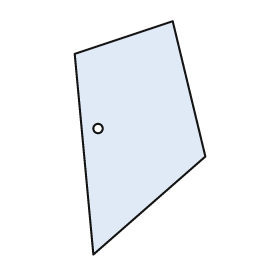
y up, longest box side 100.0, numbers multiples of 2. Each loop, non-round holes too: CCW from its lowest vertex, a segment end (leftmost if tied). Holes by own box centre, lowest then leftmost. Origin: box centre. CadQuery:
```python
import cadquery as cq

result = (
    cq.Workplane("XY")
    .moveTo(-20.0, -50.0)
    .lineTo(28.0, -8.0)
    .lineTo(14.0, 50.0)
    .lineTo(-28.0, 36.0)
    .close()
    .moveTo(-18.0, 4.0)
    .circle(2.0)
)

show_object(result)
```